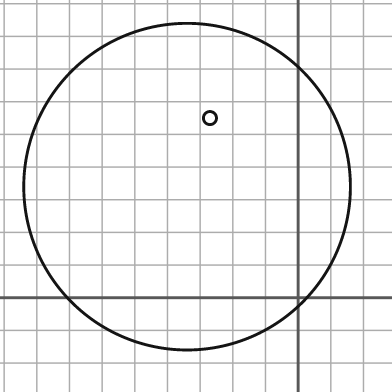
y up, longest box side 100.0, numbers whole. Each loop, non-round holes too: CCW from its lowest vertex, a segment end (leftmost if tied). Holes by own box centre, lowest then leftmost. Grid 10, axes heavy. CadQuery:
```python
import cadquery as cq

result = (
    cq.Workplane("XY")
    .moveTo(-34.0, 34.0)
    .circle(50.0)
    .moveTo(-27.0, 55.0)
    .circle(2.0)
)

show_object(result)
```